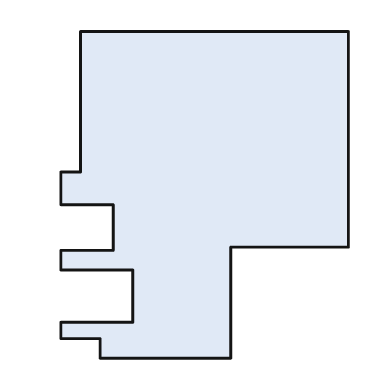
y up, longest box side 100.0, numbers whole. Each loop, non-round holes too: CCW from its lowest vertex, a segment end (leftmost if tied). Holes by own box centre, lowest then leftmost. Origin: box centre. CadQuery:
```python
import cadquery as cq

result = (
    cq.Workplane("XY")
    .moveTo(-32.0, -50.0)
    .lineTo(8.0, -50.0)
    .lineTo(8.0, -16.0)
    .lineTo(44.0, -16.0)
    .lineTo(44.0, 50.0)
    .lineTo(-38.0, 50.0)
    .lineTo(-38.0, 7.0)
    .lineTo(-44.0, 7.0)
    .lineTo(-44.0, -3.0)
    .lineTo(-28.0, -3.0)
    .lineTo(-28.0, -17.0)
    .lineTo(-44.0, -17.0)
    .lineTo(-44.0, -23.0)
    .lineTo(-22.0, -23.0)
    .lineTo(-22.0, -39.0)
    .lineTo(-44.0, -39.0)
    .lineTo(-44.0, -44.0)
    .lineTo(-32.0, -44.0)
    .close()
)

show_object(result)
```